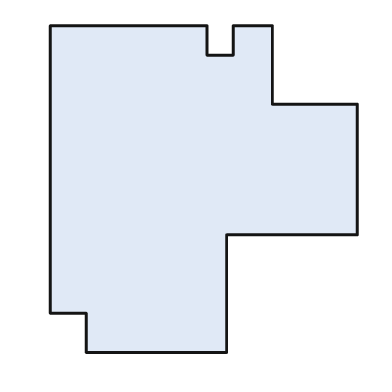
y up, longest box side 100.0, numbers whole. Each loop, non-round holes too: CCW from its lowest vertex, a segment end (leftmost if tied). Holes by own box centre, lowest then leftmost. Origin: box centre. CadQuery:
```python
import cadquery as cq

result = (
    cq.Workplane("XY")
    .moveTo(-36.0, -50.0)
    .lineTo(7.0, -50.0)
    .lineTo(7.0, -14.0)
    .lineTo(47.0, -14.0)
    .lineTo(47.0, 26.0)
    .lineTo(21.0, 26.0)
    .lineTo(21.0, 50.0)
    .lineTo(9.0, 50.0)
    .lineTo(9.0, 41.0)
    .lineTo(1.0, 41.0)
    .lineTo(1.0, 50.0)
    .lineTo(-47.0, 50.0)
    .lineTo(-47.0, -38.0)
    .lineTo(-36.0, -38.0)
    .close()
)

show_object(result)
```